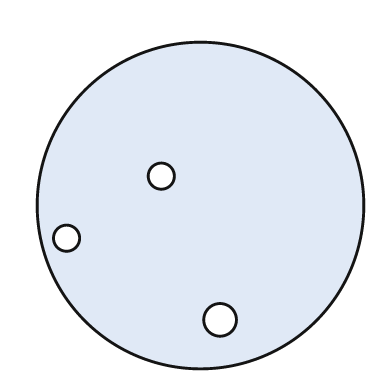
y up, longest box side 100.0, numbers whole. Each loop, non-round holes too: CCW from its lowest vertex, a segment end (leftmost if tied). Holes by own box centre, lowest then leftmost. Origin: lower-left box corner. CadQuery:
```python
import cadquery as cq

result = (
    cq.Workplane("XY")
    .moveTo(50.0, 50.0)
    .circle(50.0)
    .moveTo(56.0, 15.0)
    .circle(5.0)
    .moveTo(9.0, 40.0)
    .circle(4.0)
    .moveTo(38.0, 59.0)
    .circle(4.0)
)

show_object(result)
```